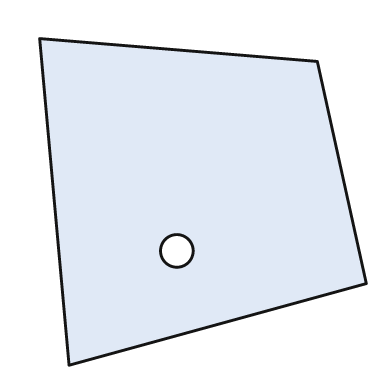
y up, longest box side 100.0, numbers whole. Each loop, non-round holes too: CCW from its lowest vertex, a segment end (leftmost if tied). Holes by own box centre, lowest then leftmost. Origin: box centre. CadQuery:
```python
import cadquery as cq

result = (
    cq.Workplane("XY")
    .moveTo(-41.0, -50.0)
    .lineTo(50.0, -25.0)
    .lineTo(35.0, 43.0)
    .lineTo(-50.0, 50.0)
    .close()
    .moveTo(-8.0, -15.0)
    .circle(5.0)
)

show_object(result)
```